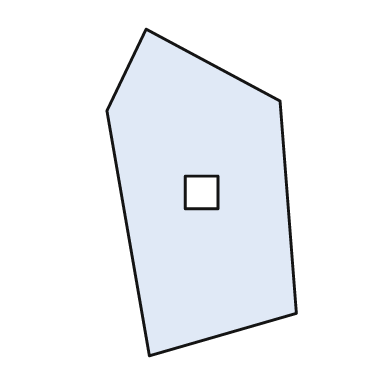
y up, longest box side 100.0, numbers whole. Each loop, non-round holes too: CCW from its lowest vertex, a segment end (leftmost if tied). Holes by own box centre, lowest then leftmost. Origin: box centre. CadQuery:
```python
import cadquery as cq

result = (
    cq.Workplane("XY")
    .moveTo(-16.0, -50.0)
    .lineTo(29.0, -37.0)
    .lineTo(24.0, 28.0)
    .lineTo(-17.0, 50.0)
    .lineTo(-29.0, 25.0)
    .close()
    .moveTo(-5.0, -5.0)
    .lineTo(5.0, -5.0)
    .lineTo(5.0, 5.0)
    .lineTo(-5.0, 5.0)
    .close()
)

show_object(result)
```